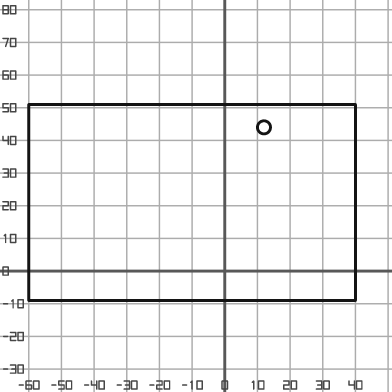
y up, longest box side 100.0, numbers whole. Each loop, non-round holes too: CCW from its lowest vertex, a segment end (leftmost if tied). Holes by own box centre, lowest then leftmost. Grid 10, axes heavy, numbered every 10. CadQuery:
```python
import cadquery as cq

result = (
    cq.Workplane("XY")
    .moveTo(-60.0, -9.0)
    .lineTo(40.0, -9.0)
    .lineTo(40.0, 51.0)
    .lineTo(-60.0, 51.0)
    .close()
    .moveTo(12.0, 44.0)
    .circle(2.0)
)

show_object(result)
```